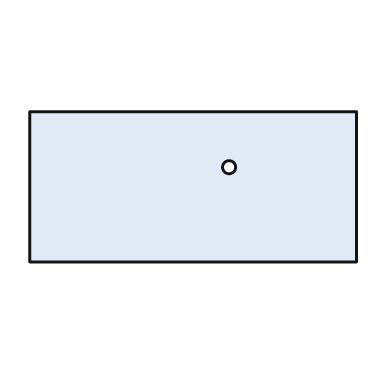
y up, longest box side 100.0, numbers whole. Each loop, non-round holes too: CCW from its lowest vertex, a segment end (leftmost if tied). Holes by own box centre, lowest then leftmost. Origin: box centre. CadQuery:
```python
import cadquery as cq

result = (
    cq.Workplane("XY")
    .moveTo(-50.0, -23.0)
    .lineTo(50.0, -23.0)
    .lineTo(50.0, 23.0)
    .lineTo(-50.0, 23.0)
    .close()
    .moveTo(11.0, 6.0)
    .circle(2.0)
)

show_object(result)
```